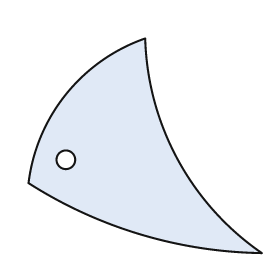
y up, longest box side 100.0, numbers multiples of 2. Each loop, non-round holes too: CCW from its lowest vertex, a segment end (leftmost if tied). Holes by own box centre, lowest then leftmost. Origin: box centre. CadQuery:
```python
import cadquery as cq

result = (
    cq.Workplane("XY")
    .moveTo(50.0, -46.0)
    .threePointArc((14.0, -6.0), (0.0, 46.0))
    .threePointArc((-34.0, 22.0), (-50.0, -16.0))
    .threePointArc((-2.0, -38.0), (50.0, -46.0))
    .close()
    .moveTo(-34.0, -6.0)
    .circle(4.0)
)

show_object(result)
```